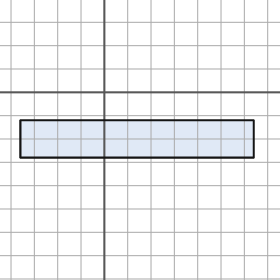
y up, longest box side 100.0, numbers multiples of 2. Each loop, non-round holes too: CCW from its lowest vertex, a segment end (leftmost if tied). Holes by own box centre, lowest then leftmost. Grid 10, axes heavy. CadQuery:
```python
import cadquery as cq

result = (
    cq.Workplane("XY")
    .moveTo(-36.0, -28.0)
    .lineTo(64.0, -28.0)
    .lineTo(64.0, -12.0)
    .lineTo(-36.0, -12.0)
    .close()
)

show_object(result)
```